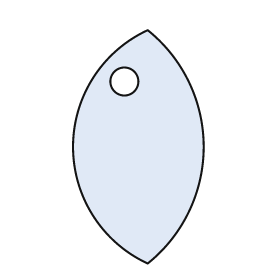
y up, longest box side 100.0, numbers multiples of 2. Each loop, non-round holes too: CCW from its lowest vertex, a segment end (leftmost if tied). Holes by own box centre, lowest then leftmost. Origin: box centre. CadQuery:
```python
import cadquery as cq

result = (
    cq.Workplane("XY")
    .moveTo(4.0, -50.0)
    .threePointArc((28.0, 0.0), (4.0, 50.0))
    .threePointArc((-28.0, 0.0), (4.0, -50.0))
    .close()
    .moveTo(-6.0, 28.0)
    .circle(6.0)
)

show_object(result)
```